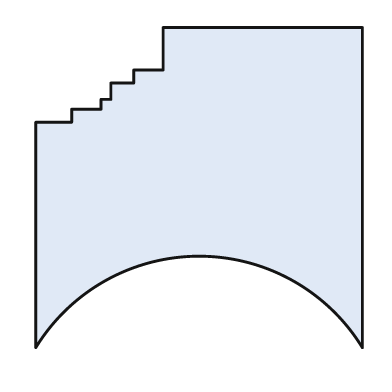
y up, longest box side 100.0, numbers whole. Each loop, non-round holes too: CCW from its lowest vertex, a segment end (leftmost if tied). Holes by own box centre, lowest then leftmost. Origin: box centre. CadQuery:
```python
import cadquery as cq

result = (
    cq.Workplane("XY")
    .moveTo(-50.0, -49.0)
    .threePointArc((0.0, -21.0), (50.0, -49.0))
    .lineTo(50.0, 49.0)
    .lineTo(-11.0, 49.0)
    .lineTo(-11.0, 36.0)
    .lineTo(-20.0, 36.0)
    .lineTo(-20.0, 32.0)
    .lineTo(-27.0, 32.0)
    .lineTo(-27.0, 27.0)
    .lineTo(-30.0, 27.0)
    .lineTo(-30.0, 24.0)
    .lineTo(-39.0, 24.0)
    .lineTo(-39.0, 20.0)
    .lineTo(-50.0, 20.0)
    .close()
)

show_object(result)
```